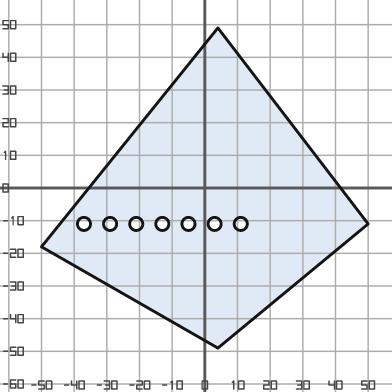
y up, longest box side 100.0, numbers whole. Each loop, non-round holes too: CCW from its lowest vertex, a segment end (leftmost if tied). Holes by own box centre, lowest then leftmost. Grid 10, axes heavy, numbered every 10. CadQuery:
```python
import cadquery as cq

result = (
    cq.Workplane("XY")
    .moveTo(4.0, -49.0)
    .lineTo(50.0, -11.0)
    .lineTo(4.0, 49.0)
    .lineTo(-50.0, -18.0)
    .close()
    .moveTo(-37.0, -11.0)
    .circle(2.0)
    .moveTo(-29.0, -11.0)
    .circle(2.0)
    .moveTo(-21.0, -11.0)
    .circle(2.0)
    .moveTo(-13.0, -11.0)
    .circle(2.0)
    .moveTo(-5.0, -11.0)
    .circle(2.0)
    .moveTo(3.0, -11.0)
    .circle(2.0)
    .moveTo(11.0, -11.0)
    .circle(2.0)
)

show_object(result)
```